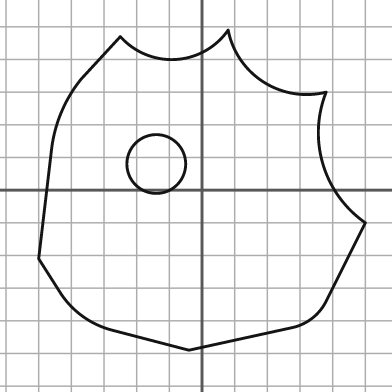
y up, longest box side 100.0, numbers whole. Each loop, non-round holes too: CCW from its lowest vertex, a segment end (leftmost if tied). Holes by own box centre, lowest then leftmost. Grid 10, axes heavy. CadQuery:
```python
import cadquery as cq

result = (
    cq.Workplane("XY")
    .moveTo(-4.0, -49.0)
    .lineTo(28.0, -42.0)
    .threePointArc((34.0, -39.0), (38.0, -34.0))
    .lineTo(50.0, -10.0)
    .threePointArc((37.0, 8.0), (38.0, 30.0))
    .threePointArc((19.0, 33.0), (8.0, 49.0))
    .threePointArc((-8.0, 40.0), (-25.0, 47.0))
    .lineTo(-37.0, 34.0)
    .threePointArc((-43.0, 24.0), (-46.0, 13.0))
    .lineTo(-50.0, -21.0)
    .lineTo(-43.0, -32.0)
    .threePointArc((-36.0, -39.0), (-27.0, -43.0))
    .close()
    .moveTo(-14.0, 8.0)
    .circle(9.0)
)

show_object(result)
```